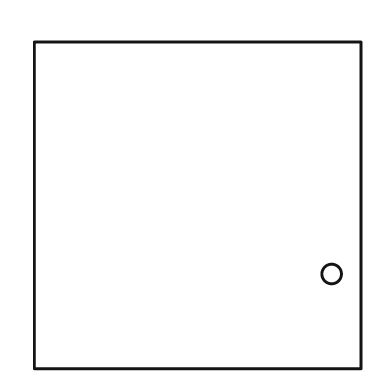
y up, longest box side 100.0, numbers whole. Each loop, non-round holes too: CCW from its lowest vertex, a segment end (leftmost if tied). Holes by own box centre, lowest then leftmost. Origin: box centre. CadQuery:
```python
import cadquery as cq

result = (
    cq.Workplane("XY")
    .moveTo(-50.0, -50.0)
    .lineTo(50.0, -50.0)
    .lineTo(50.0, 50.0)
    .lineTo(-50.0, 50.0)
    .close()
    .moveTo(41.0, -21.0)
    .circle(3.0)
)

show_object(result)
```